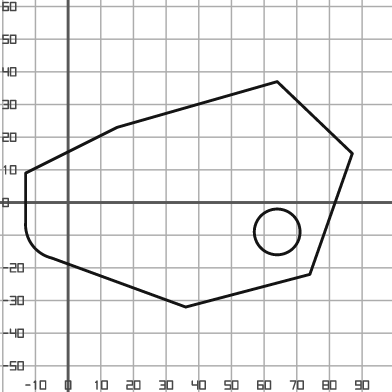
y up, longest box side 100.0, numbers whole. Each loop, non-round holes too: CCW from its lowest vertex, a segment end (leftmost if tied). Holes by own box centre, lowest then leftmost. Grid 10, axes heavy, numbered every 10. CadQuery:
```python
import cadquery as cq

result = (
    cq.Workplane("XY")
    .moveTo(36.0, -32.0)
    .lineTo(74.0, -22.0)
    .lineTo(87.0, 15.0)
    .lineTo(64.0, 37.0)
    .lineTo(15.0, 23.0)
    .lineTo(-13.0, 9.0)
    .lineTo(-13.0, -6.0)
    .threePointArc((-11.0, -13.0), (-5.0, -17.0))
    .close()
    .moveTo(64.0, -9.0)
    .circle(7.0)
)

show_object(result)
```